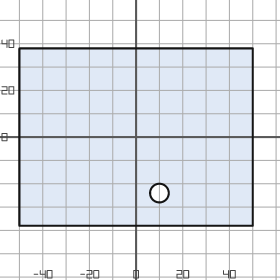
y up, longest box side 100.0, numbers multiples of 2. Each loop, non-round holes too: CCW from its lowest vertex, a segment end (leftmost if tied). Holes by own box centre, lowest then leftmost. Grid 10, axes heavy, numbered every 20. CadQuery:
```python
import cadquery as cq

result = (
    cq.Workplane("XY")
    .moveTo(-50.0, -38.0)
    .lineTo(50.0, -38.0)
    .lineTo(50.0, 38.0)
    .lineTo(-50.0, 38.0)
    .close()
    .moveTo(10.0, -24.0)
    .circle(4.0)
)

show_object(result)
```